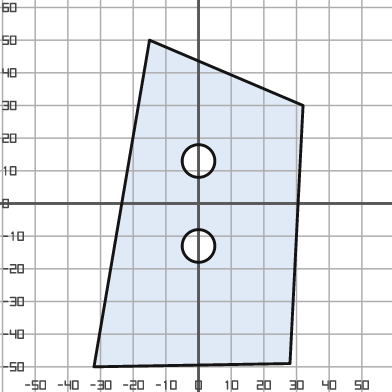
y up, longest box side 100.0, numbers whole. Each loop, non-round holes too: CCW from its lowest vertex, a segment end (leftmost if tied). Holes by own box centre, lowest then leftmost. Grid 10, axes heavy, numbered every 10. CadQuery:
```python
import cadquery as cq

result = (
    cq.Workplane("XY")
    .moveTo(-32.0, -50.0)
    .lineTo(28.0, -49.0)
    .lineTo(32.0, 30.0)
    .lineTo(-15.0, 50.0)
    .close()
    .moveTo(0.0, -13.0)
    .circle(5.0)
    .moveTo(0.0, 13.0)
    .circle(5.0)
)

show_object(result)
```